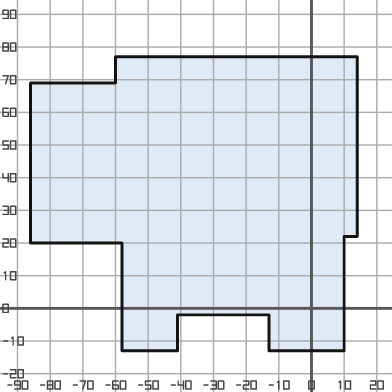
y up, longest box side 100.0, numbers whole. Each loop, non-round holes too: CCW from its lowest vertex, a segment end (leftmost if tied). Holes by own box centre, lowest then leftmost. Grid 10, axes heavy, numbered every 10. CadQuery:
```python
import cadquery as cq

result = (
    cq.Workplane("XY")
    .moveTo(-58.0, -13.0)
    .lineTo(-41.0, -13.0)
    .lineTo(-41.0, -2.0)
    .lineTo(-13.0, -2.0)
    .lineTo(-13.0, -13.0)
    .lineTo(10.0, -13.0)
    .lineTo(10.0, 22.0)
    .lineTo(14.0, 22.0)
    .lineTo(14.0, 77.0)
    .lineTo(-60.0, 77.0)
    .lineTo(-60.0, 69.0)
    .lineTo(-86.0, 69.0)
    .lineTo(-86.0, 20.0)
    .lineTo(-58.0, 20.0)
    .close()
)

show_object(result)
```